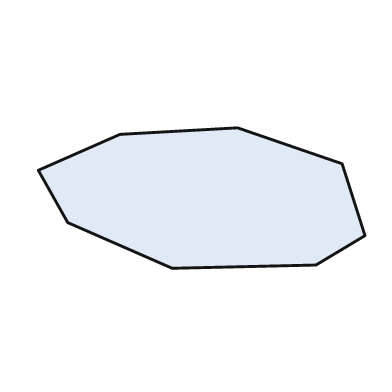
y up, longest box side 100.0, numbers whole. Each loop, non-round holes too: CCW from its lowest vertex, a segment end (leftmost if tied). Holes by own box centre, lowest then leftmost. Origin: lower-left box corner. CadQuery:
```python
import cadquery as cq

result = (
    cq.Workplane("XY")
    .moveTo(41.0, 0.0)
    .lineTo(85.0, 1.0)
    .lineTo(100.0, 10.0)
    .lineTo(93.0, 32.0)
    .lineTo(61.0, 43.0)
    .lineTo(25.0, 41.0)
    .lineTo(0.0, 30.0)
    .lineTo(9.0, 14.0)
    .close()
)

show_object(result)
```